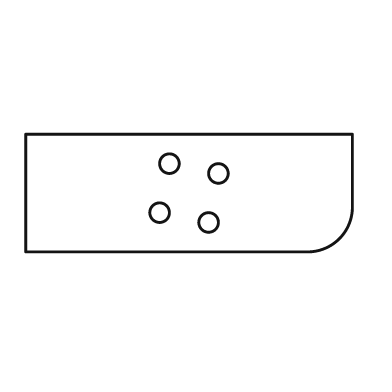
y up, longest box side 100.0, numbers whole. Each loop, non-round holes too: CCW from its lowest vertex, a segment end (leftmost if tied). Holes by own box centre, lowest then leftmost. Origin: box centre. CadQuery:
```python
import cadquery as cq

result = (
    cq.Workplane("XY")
    .moveTo(-50.0, -18.0)
    .lineTo(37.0, -18.0)
    .threePointArc((46.0, -14.0), (50.0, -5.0))
    .lineTo(50.0, 18.0)
    .lineTo(-50.0, 18.0)
    .close()
    .moveTo(6.0, -9.0)
    .circle(3.0)
    .moveTo(-9.0, -6.0)
    .circle(3.0)
    .moveTo(9.0, 6.0)
    .circle(3.0)
    .moveTo(-6.0, 9.0)
    .circle(3.0)
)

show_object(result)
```